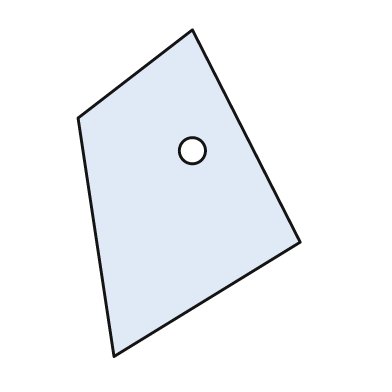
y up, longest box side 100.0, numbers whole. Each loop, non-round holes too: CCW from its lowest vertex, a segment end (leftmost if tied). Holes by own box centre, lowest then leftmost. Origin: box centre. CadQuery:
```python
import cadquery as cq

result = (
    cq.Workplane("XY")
    .moveTo(-23.0, -50.0)
    .lineTo(34.0, -15.0)
    .lineTo(1.0, 50.0)
    .lineTo(-34.0, 23.0)
    .close()
    .moveTo(1.0, 13.0)
    .circle(4.0)
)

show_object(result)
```